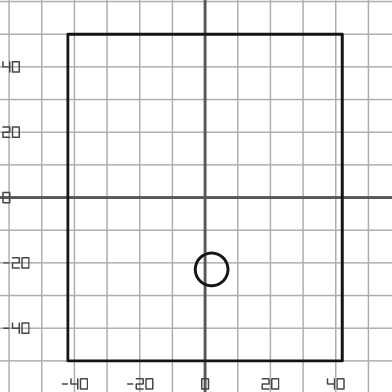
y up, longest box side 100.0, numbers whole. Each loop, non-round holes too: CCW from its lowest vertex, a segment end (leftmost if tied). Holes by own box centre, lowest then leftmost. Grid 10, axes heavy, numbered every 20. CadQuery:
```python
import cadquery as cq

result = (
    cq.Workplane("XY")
    .moveTo(-42.0, -50.0)
    .lineTo(42.0, -50.0)
    .lineTo(42.0, 50.0)
    .lineTo(-42.0, 50.0)
    .close()
    .moveTo(2.0, -22.0)
    .circle(5.0)
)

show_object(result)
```